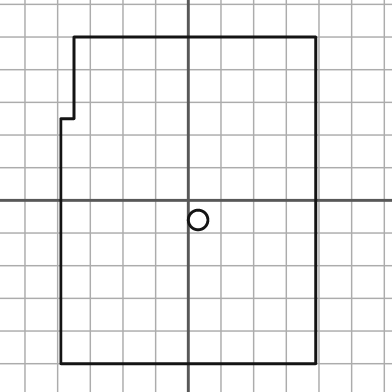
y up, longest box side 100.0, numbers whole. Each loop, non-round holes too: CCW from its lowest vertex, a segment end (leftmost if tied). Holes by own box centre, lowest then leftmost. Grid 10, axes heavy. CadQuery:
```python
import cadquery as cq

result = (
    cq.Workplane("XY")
    .moveTo(-39.0, -50.0)
    .lineTo(39.0, -50.0)
    .lineTo(39.0, 50.0)
    .lineTo(-35.0, 50.0)
    .lineTo(-35.0, 25.0)
    .lineTo(-39.0, 25.0)
    .close()
    .moveTo(3.0, -6.0)
    .circle(3.0)
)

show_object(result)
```